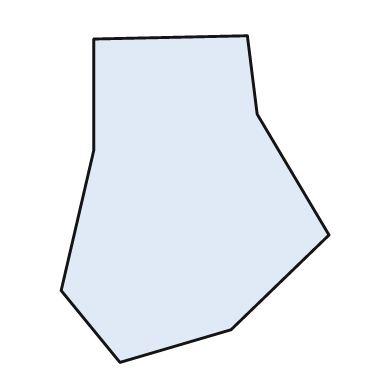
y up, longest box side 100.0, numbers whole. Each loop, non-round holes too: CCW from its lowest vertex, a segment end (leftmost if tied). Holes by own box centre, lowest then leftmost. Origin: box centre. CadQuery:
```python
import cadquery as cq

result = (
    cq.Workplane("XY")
    .moveTo(-23.0, -50.0)
    .lineTo(11.0, -40.0)
    .lineTo(41.0, -11.0)
    .lineTo(19.0, 26.0)
    .lineTo(16.0, 50.0)
    .lineTo(-31.0, 49.0)
    .lineTo(-31.0, 15.0)
    .lineTo(-41.0, -28.0)
    .close()
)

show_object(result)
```